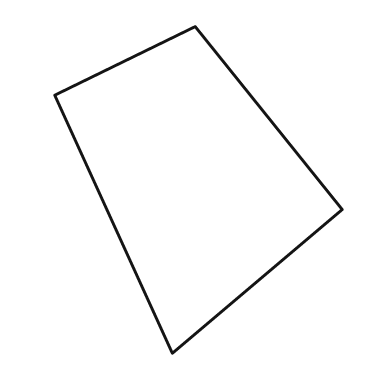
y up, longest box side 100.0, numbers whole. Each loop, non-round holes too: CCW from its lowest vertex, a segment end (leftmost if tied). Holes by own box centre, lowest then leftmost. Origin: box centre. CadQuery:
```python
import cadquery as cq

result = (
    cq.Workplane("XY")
    .moveTo(-8.0, -50.0)
    .lineTo(44.0, -6.0)
    .lineTo(-1.0, 50.0)
    .lineTo(-44.0, 29.0)
    .close()
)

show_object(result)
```